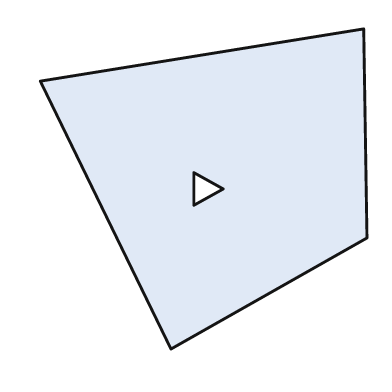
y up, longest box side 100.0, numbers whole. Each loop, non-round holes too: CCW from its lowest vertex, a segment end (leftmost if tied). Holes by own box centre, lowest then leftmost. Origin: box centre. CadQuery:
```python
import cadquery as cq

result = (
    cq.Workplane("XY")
    .moveTo(-10.0, -49.0)
    .lineTo(50.0, -15.0)
    .lineTo(49.0, 49.0)
    .lineTo(-50.0, 33.0)
    .close()
    .moveTo(-3.0, -5.0)
    .lineTo(6.0, 0.0)
    .lineTo(-3.0, 5.0)
    .close()
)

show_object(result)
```